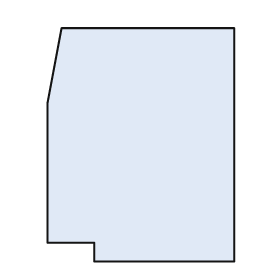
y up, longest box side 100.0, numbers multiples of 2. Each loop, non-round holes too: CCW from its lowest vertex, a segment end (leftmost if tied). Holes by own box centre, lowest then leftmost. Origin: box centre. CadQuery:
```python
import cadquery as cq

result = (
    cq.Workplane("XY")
    .moveTo(-20.0, -50.0)
    .lineTo(40.0, -50.0)
    .lineTo(40.0, 50.0)
    .lineTo(-34.0, 50.0)
    .lineTo(-40.0, 18.0)
    .lineTo(-40.0, -42.0)
    .lineTo(-20.0, -42.0)
    .close()
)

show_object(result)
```